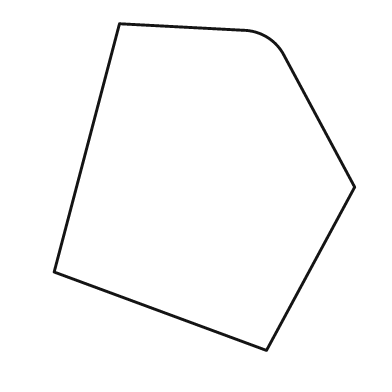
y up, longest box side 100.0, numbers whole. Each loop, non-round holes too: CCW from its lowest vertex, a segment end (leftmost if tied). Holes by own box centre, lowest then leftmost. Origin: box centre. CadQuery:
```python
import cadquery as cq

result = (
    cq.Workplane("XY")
    .moveTo(19.0, -50.0)
    .lineTo(46.0, 0.0)
    .lineTo(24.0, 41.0)
    .threePointArc((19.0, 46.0), (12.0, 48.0))
    .lineTo(-26.0, 50.0)
    .lineTo(-46.0, -26.0)
    .close()
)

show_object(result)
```